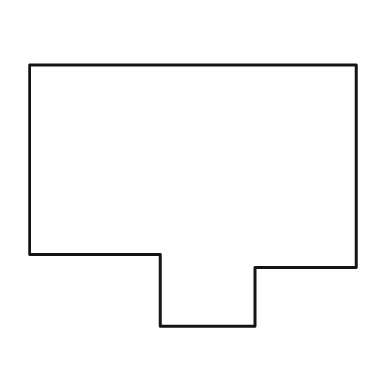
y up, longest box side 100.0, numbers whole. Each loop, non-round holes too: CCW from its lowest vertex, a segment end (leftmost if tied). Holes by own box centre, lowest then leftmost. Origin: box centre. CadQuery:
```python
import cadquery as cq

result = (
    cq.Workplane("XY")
    .moveTo(-10.0, -40.0)
    .lineTo(19.0, -40.0)
    .lineTo(19.0, -22.0)
    .lineTo(50.0, -22.0)
    .lineTo(50.0, 40.0)
    .lineTo(-50.0, 40.0)
    .lineTo(-50.0, -18.0)
    .lineTo(-10.0, -18.0)
    .close()
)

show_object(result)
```